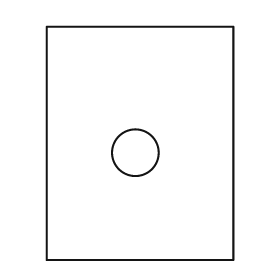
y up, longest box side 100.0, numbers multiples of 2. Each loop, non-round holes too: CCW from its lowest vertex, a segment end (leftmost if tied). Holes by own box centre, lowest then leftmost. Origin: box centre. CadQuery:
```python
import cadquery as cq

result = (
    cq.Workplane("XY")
    .moveTo(-40.0, -50.0)
    .lineTo(40.0, -50.0)
    .lineTo(40.0, 50.0)
    .lineTo(-40.0, 50.0)
    .close()
    .moveTo(-2.0, -4.0)
    .circle(10.0)
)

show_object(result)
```